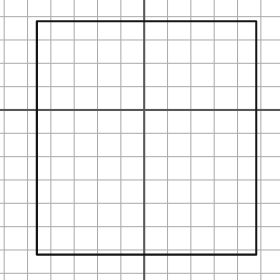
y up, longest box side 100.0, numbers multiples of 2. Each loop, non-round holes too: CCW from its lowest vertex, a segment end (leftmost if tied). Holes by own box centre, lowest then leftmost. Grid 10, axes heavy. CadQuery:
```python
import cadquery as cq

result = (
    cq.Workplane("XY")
    .moveTo(-46.0, -62.0)
    .lineTo(48.0, -62.0)
    .lineTo(48.0, 38.0)
    .lineTo(-46.0, 38.0)
    .close()
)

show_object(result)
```